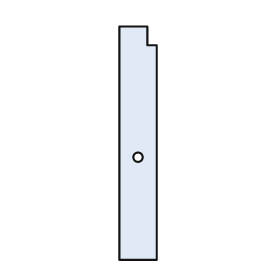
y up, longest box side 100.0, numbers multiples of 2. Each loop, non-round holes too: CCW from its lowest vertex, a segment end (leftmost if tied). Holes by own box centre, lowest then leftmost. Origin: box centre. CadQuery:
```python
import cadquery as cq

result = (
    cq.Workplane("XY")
    .moveTo(-8.0, -50.0)
    .lineTo(8.0, -50.0)
    .lineTo(8.0, 42.0)
    .lineTo(4.0, 42.0)
    .lineTo(4.0, 50.0)
    .lineTo(-8.0, 50.0)
    .close()
    .moveTo(0.0, -6.0)
    .circle(2.0)
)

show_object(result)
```